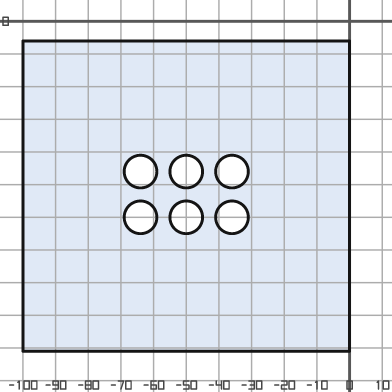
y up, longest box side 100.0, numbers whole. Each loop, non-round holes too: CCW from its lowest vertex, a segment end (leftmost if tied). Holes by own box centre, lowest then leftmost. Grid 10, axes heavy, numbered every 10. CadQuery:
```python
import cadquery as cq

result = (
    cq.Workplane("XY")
    .moveTo(-100.0, -101.0)
    .lineTo(0.0, -101.0)
    .lineTo(0.0, -6.0)
    .lineTo(-100.0, -6.0)
    .close()
    .moveTo(-64.0, -60.0)
    .circle(5.0)
    .moveTo(-50.0, -60.0)
    .circle(5.0)
    .moveTo(-36.0, -60.0)
    .circle(5.0)
    .moveTo(-64.0, -46.0)
    .circle(5.0)
    .moveTo(-50.0, -46.0)
    .circle(5.0)
    .moveTo(-36.0, -46.0)
    .circle(5.0)
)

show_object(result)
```